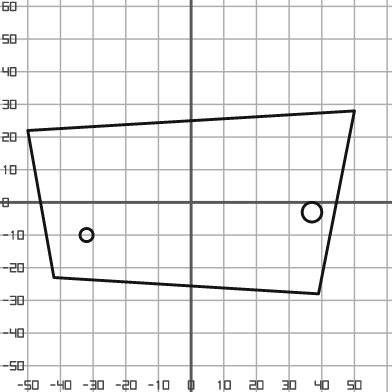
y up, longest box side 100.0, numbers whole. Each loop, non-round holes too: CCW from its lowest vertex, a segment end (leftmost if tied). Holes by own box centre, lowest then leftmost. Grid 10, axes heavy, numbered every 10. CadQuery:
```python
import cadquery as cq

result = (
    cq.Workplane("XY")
    .moveTo(39.0, -28.0)
    .lineTo(50.0, 28.0)
    .lineTo(-50.0, 22.0)
    .lineTo(-42.0, -23.0)
    .close()
    .moveTo(-32.0, -10.0)
    .circle(2.0)
    .moveTo(37.0, -3.0)
    .circle(3.0)
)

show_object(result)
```